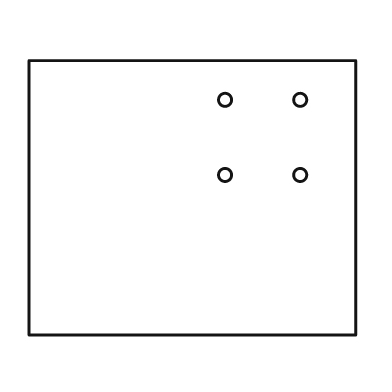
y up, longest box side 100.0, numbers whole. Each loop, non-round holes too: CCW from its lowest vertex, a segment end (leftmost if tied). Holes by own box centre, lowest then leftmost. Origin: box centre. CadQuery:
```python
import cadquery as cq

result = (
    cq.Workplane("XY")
    .moveTo(-50.0, -42.0)
    .lineTo(50.0, -42.0)
    .lineTo(50.0, 42.0)
    .lineTo(-50.0, 42.0)
    .close()
    .moveTo(10.0, 7.0)
    .circle(2.0)
    .moveTo(33.0, 7.0)
    .circle(2.0)
    .moveTo(10.0, 30.0)
    .circle(2.0)
    .moveTo(33.0, 30.0)
    .circle(2.0)
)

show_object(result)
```